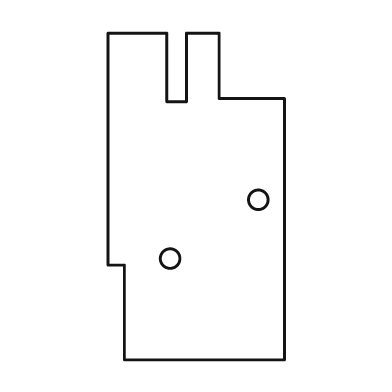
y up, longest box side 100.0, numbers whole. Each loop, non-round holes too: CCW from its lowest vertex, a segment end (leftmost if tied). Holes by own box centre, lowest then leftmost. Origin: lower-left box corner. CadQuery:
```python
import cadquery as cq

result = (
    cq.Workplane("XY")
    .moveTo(5.0, 0.0)
    .lineTo(54.0, 0.0)
    .lineTo(54.0, 80.0)
    .lineTo(34.0, 80.0)
    .lineTo(34.0, 100.0)
    .lineTo(24.0, 100.0)
    .lineTo(24.0, 79.0)
    .lineTo(18.0, 79.0)
    .lineTo(18.0, 100.0)
    .lineTo(0.0, 100.0)
    .lineTo(0.0, 29.0)
    .lineTo(5.0, 29.0)
    .close()
    .moveTo(19.0, 31.0)
    .circle(3.0)
    .moveTo(46.0, 49.0)
    .circle(3.0)
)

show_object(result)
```